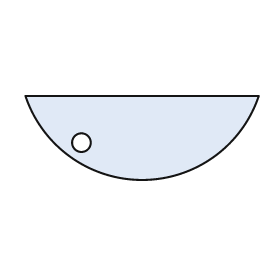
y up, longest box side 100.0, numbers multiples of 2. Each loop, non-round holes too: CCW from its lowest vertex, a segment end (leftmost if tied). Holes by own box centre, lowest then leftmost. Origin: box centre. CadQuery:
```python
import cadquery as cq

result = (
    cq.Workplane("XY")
    .moveTo(-50.0, 18.0)
    .threePointArc((0.0, -18.0), (50.0, 18.0))
    .close()
    .moveTo(-26.0, -2.0)
    .circle(4.0)
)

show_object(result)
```